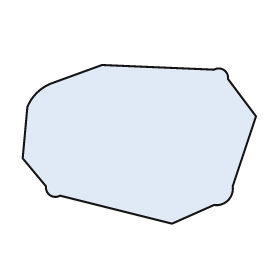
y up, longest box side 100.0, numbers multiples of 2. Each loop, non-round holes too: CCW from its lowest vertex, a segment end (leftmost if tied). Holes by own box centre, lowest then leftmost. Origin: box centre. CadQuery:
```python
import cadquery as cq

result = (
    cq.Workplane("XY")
    .moveTo(14.0, -34.0)
    .lineTo(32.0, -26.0)
    .threePointArc((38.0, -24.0), (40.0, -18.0))
    .lineTo(50.0, 12.0)
    .lineTo(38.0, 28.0)
    .threePointArc((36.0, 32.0), (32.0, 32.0))
    .lineTo(-16.0, 34.0)
    .lineTo(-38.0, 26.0)
    .threePointArc((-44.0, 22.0), (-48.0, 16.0))
    .lineTo(-50.0, -6.0)
    .lineTo(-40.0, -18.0)
    .threePointArc((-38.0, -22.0), (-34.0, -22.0))
    .close()
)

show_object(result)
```